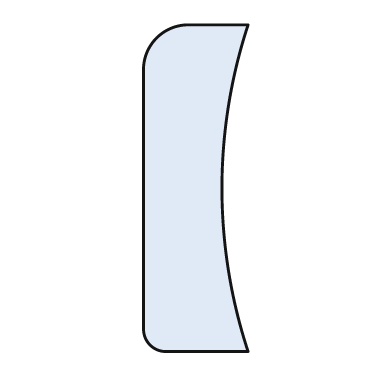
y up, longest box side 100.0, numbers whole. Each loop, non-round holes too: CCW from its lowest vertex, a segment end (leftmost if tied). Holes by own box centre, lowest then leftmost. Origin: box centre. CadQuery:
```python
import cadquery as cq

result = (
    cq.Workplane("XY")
    .moveTo(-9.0, -50.0)
    .lineTo(16.0, -50.0)
    .threePointArc((8.0, 0.0), (16.0, 50.0))
    .lineTo(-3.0, 50.0)
    .threePointArc((-12.0, 46.0), (-16.0, 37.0))
    .lineTo(-16.0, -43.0)
    .threePointArc((-14.0, -48.0), (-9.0, -50.0))
    .close()
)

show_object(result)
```